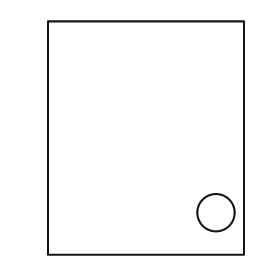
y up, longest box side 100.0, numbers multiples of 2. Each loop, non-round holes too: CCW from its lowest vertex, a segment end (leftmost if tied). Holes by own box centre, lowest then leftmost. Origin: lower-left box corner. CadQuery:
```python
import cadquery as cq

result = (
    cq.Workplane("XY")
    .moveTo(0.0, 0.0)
    .lineTo(84.0, 0.0)
    .lineTo(84.0, 100.0)
    .lineTo(0.0, 100.0)
    .close()
    .moveTo(72.0, 18.0)
    .circle(8.0)
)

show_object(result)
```